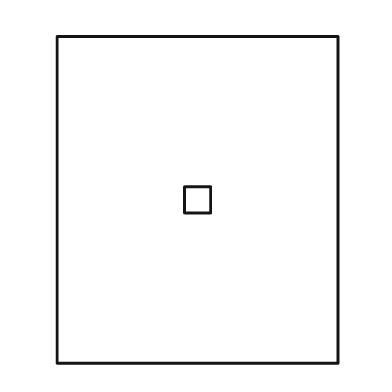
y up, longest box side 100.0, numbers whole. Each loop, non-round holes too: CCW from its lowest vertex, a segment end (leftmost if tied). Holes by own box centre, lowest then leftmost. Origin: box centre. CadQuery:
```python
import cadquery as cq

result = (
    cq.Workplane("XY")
    .moveTo(-43.0, -50.0)
    .lineTo(43.0, -50.0)
    .lineTo(43.0, 50.0)
    .lineTo(-43.0, 50.0)
    .close()
    .moveTo(-4.0, -4.0)
    .lineTo(4.0, -4.0)
    .lineTo(4.0, 4.0)
    .lineTo(-4.0, 4.0)
    .close()
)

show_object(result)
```